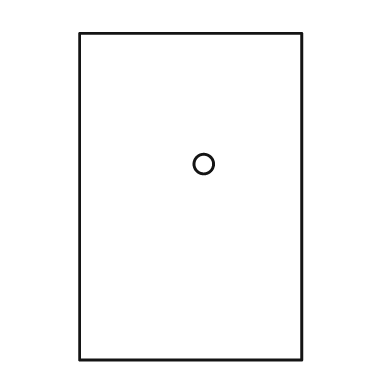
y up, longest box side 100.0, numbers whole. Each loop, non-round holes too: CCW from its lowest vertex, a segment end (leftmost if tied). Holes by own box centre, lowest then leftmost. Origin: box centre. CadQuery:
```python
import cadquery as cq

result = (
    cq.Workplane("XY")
    .moveTo(-34.0, -50.0)
    .lineTo(34.0, -50.0)
    .lineTo(34.0, 50.0)
    .lineTo(-34.0, 50.0)
    .close()
    .moveTo(4.0, 10.0)
    .circle(3.0)
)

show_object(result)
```